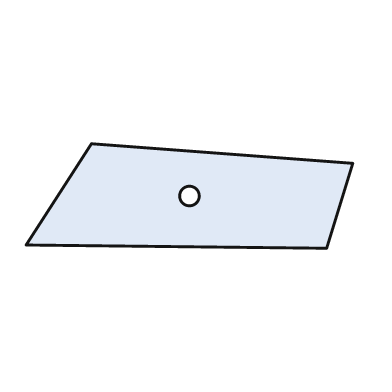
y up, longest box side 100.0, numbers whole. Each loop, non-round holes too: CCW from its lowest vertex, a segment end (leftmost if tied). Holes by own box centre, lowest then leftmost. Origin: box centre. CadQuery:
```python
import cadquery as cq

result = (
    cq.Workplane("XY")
    .moveTo(42.0, -16.0)
    .lineTo(50.0, 10.0)
    .lineTo(-30.0, 16.0)
    .lineTo(-50.0, -15.0)
    .close()
    .moveTo(0.0, 0.0)
    .circle(3.0)
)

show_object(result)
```